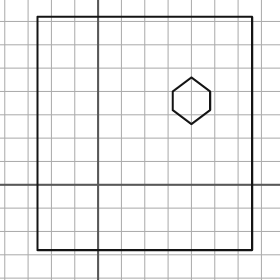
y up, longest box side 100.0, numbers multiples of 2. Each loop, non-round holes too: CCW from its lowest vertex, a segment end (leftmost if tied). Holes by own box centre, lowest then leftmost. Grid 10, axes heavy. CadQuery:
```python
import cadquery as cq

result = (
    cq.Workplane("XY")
    .moveTo(-26.0, -28.0)
    .lineTo(66.0, -28.0)
    .lineTo(66.0, 72.0)
    .lineTo(-26.0, 72.0)
    .close()
    .moveTo(40.0, 26.0)
    .lineTo(48.0, 32.0)
    .lineTo(48.0, 40.0)
    .lineTo(40.0, 46.0)
    .lineTo(32.0, 40.0)
    .lineTo(32.0, 32.0)
    .close()
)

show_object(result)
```